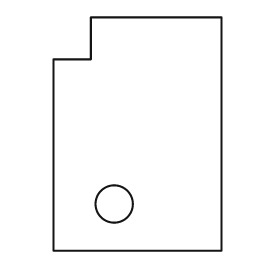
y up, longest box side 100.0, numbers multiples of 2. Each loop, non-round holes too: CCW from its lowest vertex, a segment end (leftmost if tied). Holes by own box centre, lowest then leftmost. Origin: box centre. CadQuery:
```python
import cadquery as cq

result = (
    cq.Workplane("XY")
    .moveTo(-36.0, -50.0)
    .lineTo(36.0, -50.0)
    .lineTo(36.0, 50.0)
    .lineTo(-20.0, 50.0)
    .lineTo(-20.0, 32.0)
    .lineTo(-36.0, 32.0)
    .close()
    .moveTo(-10.0, -30.0)
    .circle(8.0)
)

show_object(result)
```